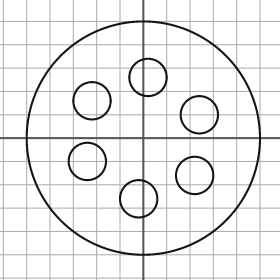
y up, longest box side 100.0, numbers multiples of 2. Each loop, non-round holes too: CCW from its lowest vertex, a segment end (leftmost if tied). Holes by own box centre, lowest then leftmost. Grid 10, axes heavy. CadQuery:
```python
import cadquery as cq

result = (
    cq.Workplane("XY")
    .moveTo(0.0, 0.0)
    .circle(50.0)
    .moveTo(-2.0, -26.0)
    .circle(8.0)
    .moveTo(22.0, -16.0)
    .circle(8.0)
    .moveTo(-24.0, -10.0)
    .circle(8.0)
    .moveTo(24.0, 10.0)
    .circle(8.0)
    .moveTo(-22.0, 16.0)
    .circle(8.0)
    .moveTo(2.0, 26.0)
    .circle(8.0)
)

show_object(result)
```